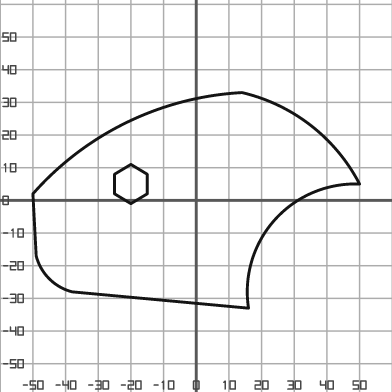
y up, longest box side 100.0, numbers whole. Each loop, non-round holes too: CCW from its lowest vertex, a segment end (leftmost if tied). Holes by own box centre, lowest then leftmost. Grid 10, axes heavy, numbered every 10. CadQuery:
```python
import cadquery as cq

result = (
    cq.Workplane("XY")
    .moveTo(16.0, -33.0)
    .threePointArc((24.0, -6.0), (50.0, 5.0))
    .threePointArc((35.0, 23.0), (14.0, 33.0))
    .threePointArc((-21.0, 24.0), (-50.0, 2.0))
    .lineTo(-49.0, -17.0)
    .threePointArc((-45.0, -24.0), (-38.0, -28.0))
    .close()
    .moveTo(-20.0, -1.0)
    .lineTo(-15.0, 2.0)
    .lineTo(-15.0, 8.0)
    .lineTo(-20.0, 11.0)
    .lineTo(-25.0, 8.0)
    .lineTo(-25.0, 2.0)
    .close()
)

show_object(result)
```